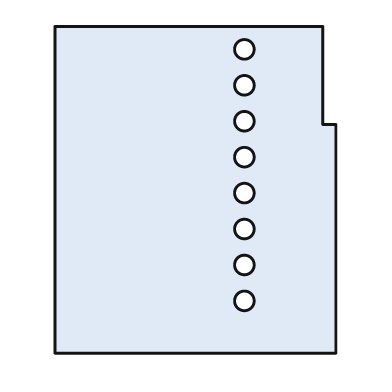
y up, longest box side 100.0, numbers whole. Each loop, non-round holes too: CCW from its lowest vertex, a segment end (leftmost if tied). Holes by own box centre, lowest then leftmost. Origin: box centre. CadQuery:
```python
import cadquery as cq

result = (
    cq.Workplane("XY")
    .moveTo(-43.0, -50.0)
    .lineTo(43.0, -50.0)
    .lineTo(43.0, 20.0)
    .lineTo(39.0, 20.0)
    .lineTo(39.0, 50.0)
    .lineTo(-43.0, 50.0)
    .close()
    .moveTo(15.0, -34.0)
    .circle(3.0)
    .moveTo(15.0, -23.0)
    .circle(3.0)
    .moveTo(15.0, -12.0)
    .circle(3.0)
    .moveTo(15.0, -1.0)
    .circle(3.0)
    .moveTo(15.0, 10.0)
    .circle(3.0)
    .moveTo(15.0, 21.0)
    .circle(3.0)
    .moveTo(15.0, 32.0)
    .circle(3.0)
    .moveTo(15.0, 43.0)
    .circle(3.0)
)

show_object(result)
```